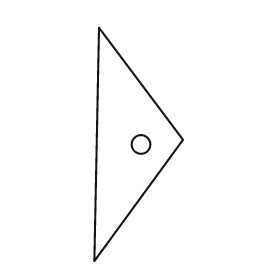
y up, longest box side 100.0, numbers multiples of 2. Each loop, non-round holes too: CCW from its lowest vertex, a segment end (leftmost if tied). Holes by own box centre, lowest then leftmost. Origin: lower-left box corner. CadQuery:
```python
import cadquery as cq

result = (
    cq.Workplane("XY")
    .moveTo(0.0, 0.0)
    .lineTo(38.0, 52.0)
    .lineTo(2.0, 100.0)
    .close()
    .moveTo(20.0, 50.0)
    .circle(4.0)
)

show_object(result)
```